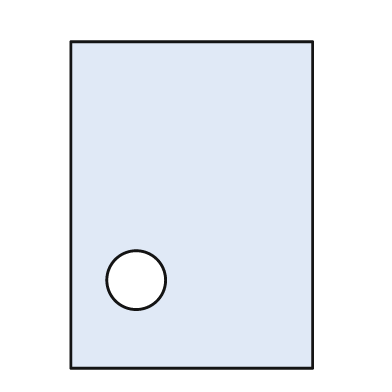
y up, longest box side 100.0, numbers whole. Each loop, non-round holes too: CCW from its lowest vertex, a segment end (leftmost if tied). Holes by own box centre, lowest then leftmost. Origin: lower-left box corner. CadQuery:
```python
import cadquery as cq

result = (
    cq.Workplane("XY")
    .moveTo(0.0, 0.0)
    .lineTo(74.0, 0.0)
    .lineTo(74.0, 100.0)
    .lineTo(0.0, 100.0)
    .close()
    .moveTo(20.0, 27.0)
    .circle(9.0)
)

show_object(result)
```